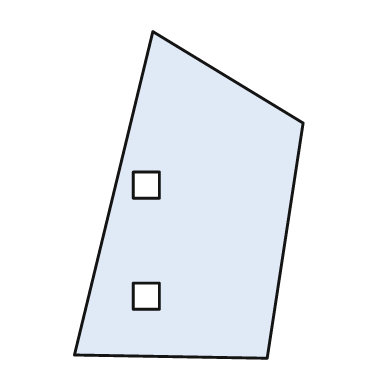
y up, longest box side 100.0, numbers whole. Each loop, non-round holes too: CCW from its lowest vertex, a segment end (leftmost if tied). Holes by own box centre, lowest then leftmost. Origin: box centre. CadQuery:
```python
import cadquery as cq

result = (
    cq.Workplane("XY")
    .moveTo(24.0, -50.0)
    .lineTo(35.0, 22.0)
    .lineTo(-11.0, 50.0)
    .lineTo(-35.0, -49.0)
    .close()
    .moveTo(-17.0, -35.0)
    .lineTo(-9.0, -35.0)
    .lineTo(-9.0, -27.0)
    .lineTo(-17.0, -27.0)
    .close()
    .moveTo(-17.0, -1.0)
    .lineTo(-9.0, -1.0)
    .lineTo(-9.0, 7.0)
    .lineTo(-17.0, 7.0)
    .close()
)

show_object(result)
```